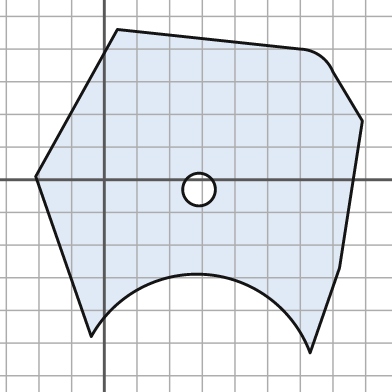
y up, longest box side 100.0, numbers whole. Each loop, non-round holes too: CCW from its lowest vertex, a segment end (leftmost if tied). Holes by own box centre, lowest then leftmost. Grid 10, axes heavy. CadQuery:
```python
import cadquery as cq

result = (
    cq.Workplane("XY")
    .moveTo(63.0, -53.0)
    .lineTo(72.0, -27.0)
    .lineTo(79.0, 18.0)
    .lineTo(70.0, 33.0)
    .threePointArc((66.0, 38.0), (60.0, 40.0))
    .lineTo(4.0, 46.0)
    .lineTo(-21.0, 1.0)
    .lineTo(-4.0, -48.0)
    .threePointArc((31.0, -29.0), (63.0, -53.0))
    .close()
    .moveTo(29.0, -3.0)
    .circle(5.0)
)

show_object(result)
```